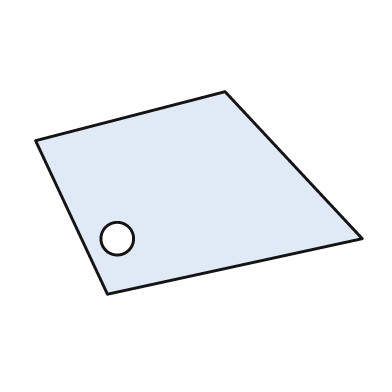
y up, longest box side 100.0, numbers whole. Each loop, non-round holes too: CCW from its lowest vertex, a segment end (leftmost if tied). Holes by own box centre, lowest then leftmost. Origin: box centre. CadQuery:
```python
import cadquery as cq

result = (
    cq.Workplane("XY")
    .moveTo(-28.0, -31.0)
    .lineTo(50.0, -14.0)
    .lineTo(8.0, 31.0)
    .lineTo(-50.0, 16.0)
    .close()
    .moveTo(-25.0, -14.0)
    .circle(5.0)
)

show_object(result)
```